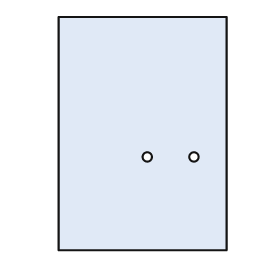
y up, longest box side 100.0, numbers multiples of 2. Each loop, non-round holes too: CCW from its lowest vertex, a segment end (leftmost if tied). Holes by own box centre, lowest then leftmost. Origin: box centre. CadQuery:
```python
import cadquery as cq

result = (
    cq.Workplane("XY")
    .moveTo(-36.0, -50.0)
    .lineTo(36.0, -50.0)
    .lineTo(36.0, 50.0)
    .lineTo(-36.0, 50.0)
    .close()
    .moveTo(2.0, -10.0)
    .circle(2.0)
    .moveTo(22.0, -10.0)
    .circle(2.0)
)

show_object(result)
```